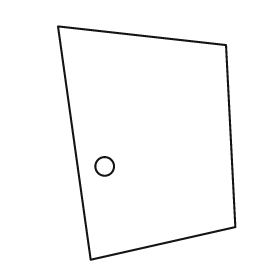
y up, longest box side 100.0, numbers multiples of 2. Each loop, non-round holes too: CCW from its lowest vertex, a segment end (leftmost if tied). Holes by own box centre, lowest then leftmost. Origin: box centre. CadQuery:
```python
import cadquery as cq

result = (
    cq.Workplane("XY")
    .moveTo(-24.0, -50.0)
    .lineTo(38.0, -36.0)
    .lineTo(34.0, 42.0)
    .lineTo(-38.0, 50.0)
    .close()
    .moveTo(-18.0, -10.0)
    .circle(4.0)
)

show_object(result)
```